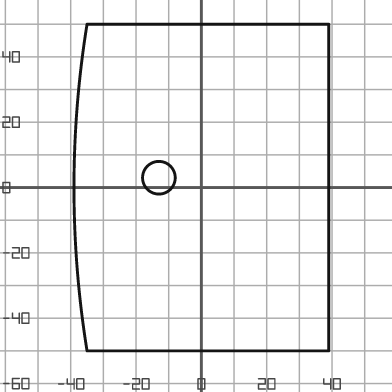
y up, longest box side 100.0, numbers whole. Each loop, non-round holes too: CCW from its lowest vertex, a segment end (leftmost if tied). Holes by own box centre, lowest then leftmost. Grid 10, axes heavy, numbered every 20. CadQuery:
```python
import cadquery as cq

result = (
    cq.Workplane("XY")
    .moveTo(-35.0, -50.0)
    .lineTo(39.0, -50.0)
    .lineTo(39.0, 50.0)
    .lineTo(-35.0, 50.0)
    .threePointArc((-39.0, 0.0), (-35.0, -50.0))
    .close()
    .moveTo(-13.0, 3.0)
    .circle(5.0)
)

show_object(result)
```